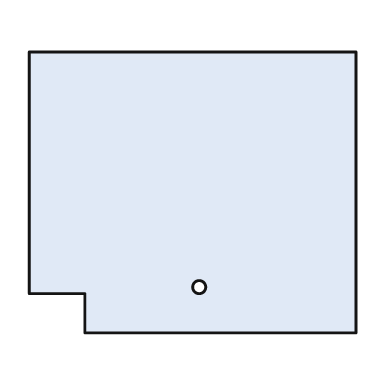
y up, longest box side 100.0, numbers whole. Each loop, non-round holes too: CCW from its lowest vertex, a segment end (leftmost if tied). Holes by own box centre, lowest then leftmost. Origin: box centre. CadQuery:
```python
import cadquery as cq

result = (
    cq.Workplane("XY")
    .moveTo(-33.0, -43.0)
    .lineTo(50.0, -43.0)
    .lineTo(50.0, 43.0)
    .lineTo(-50.0, 43.0)
    .lineTo(-50.0, -31.0)
    .lineTo(-33.0, -31.0)
    .close()
    .moveTo(2.0, -29.0)
    .circle(2.0)
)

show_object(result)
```